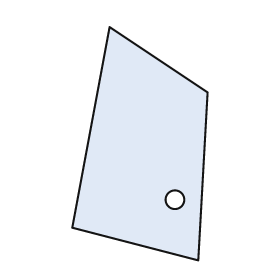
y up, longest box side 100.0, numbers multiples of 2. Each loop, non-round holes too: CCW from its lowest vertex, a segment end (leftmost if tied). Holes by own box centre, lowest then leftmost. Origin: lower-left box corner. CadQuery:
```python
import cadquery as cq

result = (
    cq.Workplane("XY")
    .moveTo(54.0, 0.0)
    .lineTo(58.0, 72.0)
    .lineTo(16.0, 100.0)
    .lineTo(0.0, 14.0)
    .close()
    .moveTo(44.0, 26.0)
    .circle(4.0)
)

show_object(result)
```